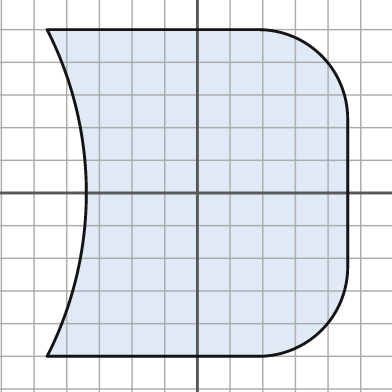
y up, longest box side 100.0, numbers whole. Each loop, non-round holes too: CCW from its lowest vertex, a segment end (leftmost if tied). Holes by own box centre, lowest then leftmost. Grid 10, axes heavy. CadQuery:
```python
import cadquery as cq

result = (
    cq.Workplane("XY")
    .moveTo(-46.0, -50.0)
    .lineTo(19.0, -50.0)
    .threePointArc((38.0, -42.0), (46.0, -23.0))
    .lineTo(46.0, 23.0)
    .threePointArc((38.0, 42.0), (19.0, 50.0))
    .lineTo(-46.0, 50.0)
    .threePointArc((-34.0, 0.0), (-46.0, -50.0))
    .close()
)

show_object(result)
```